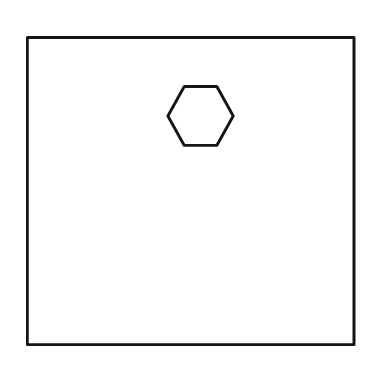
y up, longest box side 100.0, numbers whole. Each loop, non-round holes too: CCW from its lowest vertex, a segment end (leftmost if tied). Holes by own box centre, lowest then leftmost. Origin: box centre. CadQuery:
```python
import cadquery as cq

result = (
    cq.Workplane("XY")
    .moveTo(-50.0, -47.0)
    .lineTo(50.0, -47.0)
    .lineTo(50.0, 47.0)
    .lineTo(-50.0, 47.0)
    .close()
    .moveTo(-2.0, 14.0)
    .lineTo(8.0, 14.0)
    .lineTo(13.0, 23.0)
    .lineTo(8.0, 32.0)
    .lineTo(-2.0, 32.0)
    .lineTo(-7.0, 23.0)
    .close()
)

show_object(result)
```